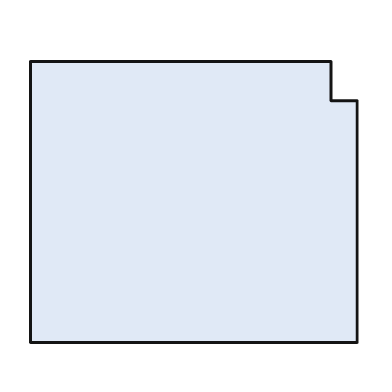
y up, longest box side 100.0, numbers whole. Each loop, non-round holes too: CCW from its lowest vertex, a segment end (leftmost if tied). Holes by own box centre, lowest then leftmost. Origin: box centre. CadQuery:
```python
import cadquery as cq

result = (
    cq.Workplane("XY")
    .moveTo(-50.0, -43.0)
    .lineTo(50.0, -43.0)
    .lineTo(50.0, 31.0)
    .lineTo(42.0, 31.0)
    .lineTo(42.0, 43.0)
    .lineTo(-50.0, 43.0)
    .close()
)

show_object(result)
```